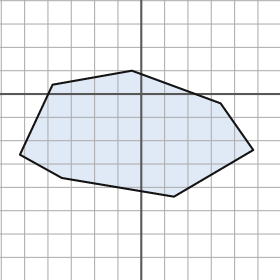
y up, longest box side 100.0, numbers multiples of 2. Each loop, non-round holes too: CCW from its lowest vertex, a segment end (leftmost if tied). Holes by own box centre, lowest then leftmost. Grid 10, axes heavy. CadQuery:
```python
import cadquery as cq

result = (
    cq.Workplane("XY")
    .moveTo(14.0, -44.0)
    .lineTo(48.0, -24.0)
    .lineTo(34.0, -4.0)
    .lineTo(-4.0, 10.0)
    .lineTo(-38.0, 4.0)
    .lineTo(-52.0, -26.0)
    .lineTo(-34.0, -36.0)
    .close()
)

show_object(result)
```